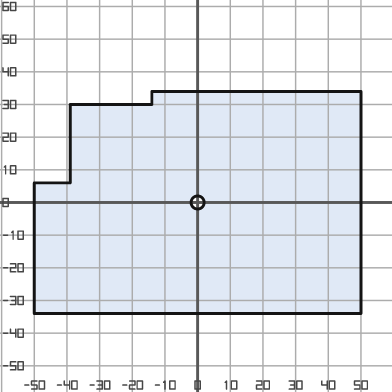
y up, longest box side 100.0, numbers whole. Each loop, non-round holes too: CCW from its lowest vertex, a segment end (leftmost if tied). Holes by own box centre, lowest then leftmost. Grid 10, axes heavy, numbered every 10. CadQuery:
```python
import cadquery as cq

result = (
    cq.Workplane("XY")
    .moveTo(-50.0, -34.0)
    .lineTo(50.0, -34.0)
    .lineTo(50.0, 34.0)
    .lineTo(-14.0, 34.0)
    .lineTo(-14.0, 30.0)
    .lineTo(-39.0, 30.0)
    .lineTo(-39.0, 6.0)
    .lineTo(-50.0, 6.0)
    .close()
    .moveTo(0.0, 0.0)
    .circle(2.0)
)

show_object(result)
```